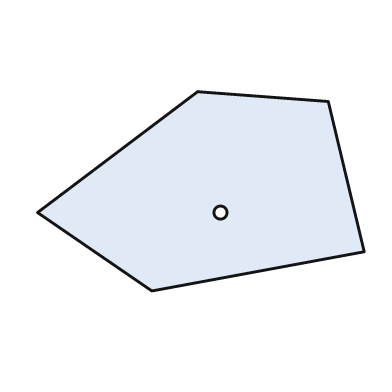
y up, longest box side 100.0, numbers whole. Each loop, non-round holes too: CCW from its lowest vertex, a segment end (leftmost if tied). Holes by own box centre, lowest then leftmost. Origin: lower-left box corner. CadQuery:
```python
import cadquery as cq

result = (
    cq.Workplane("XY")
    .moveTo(35.0, 0.0)
    .lineTo(100.0, 12.0)
    .lineTo(89.0, 58.0)
    .lineTo(49.0, 61.0)
    .lineTo(0.0, 24.0)
    .close()
    .moveTo(56.0, 24.0)
    .circle(2.0)
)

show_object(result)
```